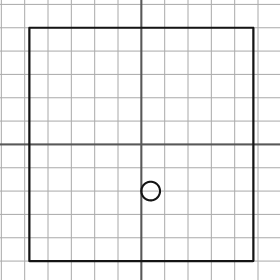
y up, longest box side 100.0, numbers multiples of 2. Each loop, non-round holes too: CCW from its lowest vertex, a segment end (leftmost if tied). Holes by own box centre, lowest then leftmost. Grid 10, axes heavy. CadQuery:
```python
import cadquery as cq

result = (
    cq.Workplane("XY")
    .moveTo(-48.0, -50.0)
    .lineTo(48.0, -50.0)
    .lineTo(48.0, 50.0)
    .lineTo(-48.0, 50.0)
    .close()
    .moveTo(4.0, -20.0)
    .circle(4.0)
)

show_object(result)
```